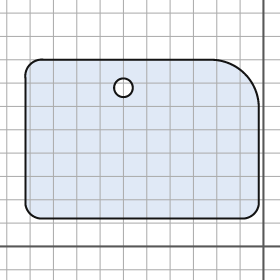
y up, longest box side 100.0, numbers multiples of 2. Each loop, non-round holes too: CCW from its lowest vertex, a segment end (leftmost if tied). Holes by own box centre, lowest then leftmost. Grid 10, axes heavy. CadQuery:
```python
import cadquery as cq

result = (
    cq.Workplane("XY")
    .moveTo(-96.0, 12.0)
    .lineTo(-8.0, 12.0)
    .threePointArc((-4.0, 14.0), (-2.0, 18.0))
    .lineTo(-2.0, 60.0)
    .threePointArc((-8.0, 74.0), (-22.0, 80.0))
    .lineTo(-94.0, 80.0)
    .threePointArc((-100.0, 78.0), (-102.0, 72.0))
    .lineTo(-102.0, 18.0)
    .threePointArc((-100.0, 14.0), (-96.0, 12.0))
    .close()
    .moveTo(-60.0, 68.0)
    .circle(4.0)
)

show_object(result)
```